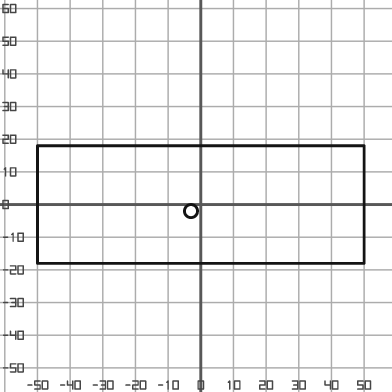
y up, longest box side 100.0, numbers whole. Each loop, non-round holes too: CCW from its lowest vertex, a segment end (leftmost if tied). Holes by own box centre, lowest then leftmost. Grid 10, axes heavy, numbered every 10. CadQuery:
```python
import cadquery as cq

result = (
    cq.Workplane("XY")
    .moveTo(-50.0, -18.0)
    .lineTo(50.0, -18.0)
    .lineTo(50.0, 18.0)
    .lineTo(-50.0, 18.0)
    .close()
    .moveTo(-3.0, -2.0)
    .circle(2.0)
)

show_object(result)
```